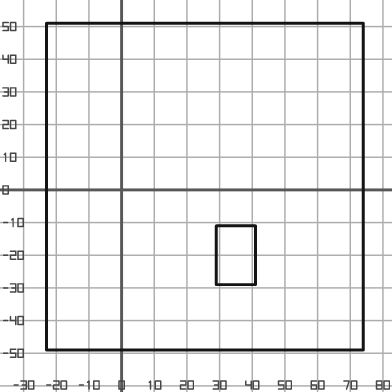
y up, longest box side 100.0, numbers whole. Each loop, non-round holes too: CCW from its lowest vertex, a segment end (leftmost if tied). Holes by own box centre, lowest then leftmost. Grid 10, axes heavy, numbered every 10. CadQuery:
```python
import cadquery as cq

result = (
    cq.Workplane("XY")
    .moveTo(-23.0, -49.0)
    .lineTo(74.0, -49.0)
    .lineTo(74.0, 51.0)
    .lineTo(-23.0, 51.0)
    .close()
    .moveTo(29.0, -29.0)
    .lineTo(41.0, -29.0)
    .lineTo(41.0, -11.0)
    .lineTo(29.0, -11.0)
    .close()
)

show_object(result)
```